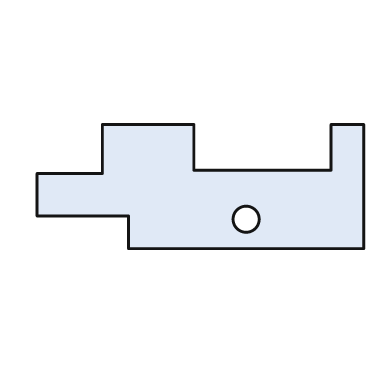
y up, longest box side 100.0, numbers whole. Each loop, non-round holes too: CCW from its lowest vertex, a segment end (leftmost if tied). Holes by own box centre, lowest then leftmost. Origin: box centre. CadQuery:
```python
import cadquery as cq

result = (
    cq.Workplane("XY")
    .moveTo(-22.0, -19.0)
    .lineTo(50.0, -19.0)
    .lineTo(50.0, 19.0)
    .lineTo(40.0, 19.0)
    .lineTo(40.0, 5.0)
    .lineTo(-2.0, 5.0)
    .lineTo(-2.0, 19.0)
    .lineTo(-30.0, 19.0)
    .lineTo(-30.0, 4.0)
    .lineTo(-50.0, 4.0)
    .lineTo(-50.0, -9.0)
    .lineTo(-22.0, -9.0)
    .close()
    .moveTo(14.0, -10.0)
    .circle(4.0)
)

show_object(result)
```